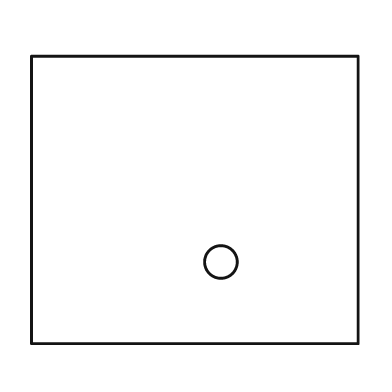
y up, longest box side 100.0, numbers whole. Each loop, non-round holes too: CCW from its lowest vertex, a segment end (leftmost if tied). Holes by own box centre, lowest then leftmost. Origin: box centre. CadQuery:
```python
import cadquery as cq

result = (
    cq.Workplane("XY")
    .moveTo(-50.0, -44.0)
    .lineTo(50.0, -44.0)
    .lineTo(50.0, 44.0)
    .lineTo(-50.0, 44.0)
    .close()
    .moveTo(8.0, -19.0)
    .circle(5.0)
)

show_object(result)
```